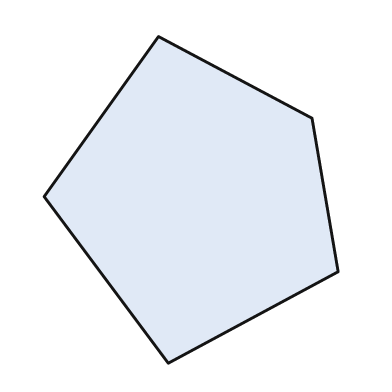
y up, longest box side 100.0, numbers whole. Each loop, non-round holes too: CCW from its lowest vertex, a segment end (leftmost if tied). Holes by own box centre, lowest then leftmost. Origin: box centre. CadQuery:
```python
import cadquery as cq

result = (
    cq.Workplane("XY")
    .moveTo(-7.0, -50.0)
    .lineTo(45.0, -22.0)
    .lineTo(37.0, 25.0)
    .lineTo(-10.0, 50.0)
    .lineTo(-45.0, 1.0)
    .close()
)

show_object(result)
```